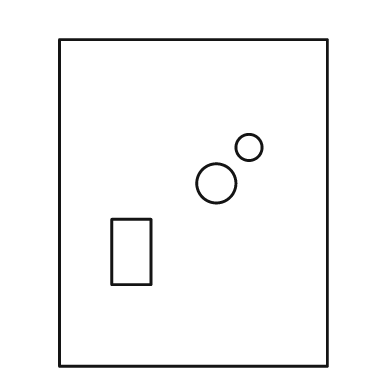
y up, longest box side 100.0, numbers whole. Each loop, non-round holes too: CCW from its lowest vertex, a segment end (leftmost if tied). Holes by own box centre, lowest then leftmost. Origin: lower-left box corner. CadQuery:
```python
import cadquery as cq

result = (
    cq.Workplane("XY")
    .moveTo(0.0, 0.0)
    .lineTo(82.0, 0.0)
    .lineTo(82.0, 100.0)
    .lineTo(0.0, 100.0)
    .close()
    .moveTo(16.0, 25.0)
    .lineTo(28.0, 25.0)
    .lineTo(28.0, 45.0)
    .lineTo(16.0, 45.0)
    .close()
    .moveTo(48.0, 56.0)
    .circle(6.0)
    .moveTo(58.0, 67.0)
    .circle(4.0)
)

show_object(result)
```